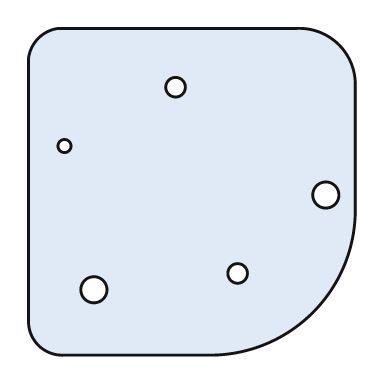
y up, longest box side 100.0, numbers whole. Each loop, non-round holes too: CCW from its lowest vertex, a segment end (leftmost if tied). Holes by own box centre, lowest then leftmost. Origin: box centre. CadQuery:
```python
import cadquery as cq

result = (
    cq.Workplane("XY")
    .moveTo(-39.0, -50.0)
    .lineTo(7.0, -50.0)
    .threePointArc((37.0, -37.0), (50.0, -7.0))
    .lineTo(50.0, 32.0)
    .threePointArc((45.0, 45.0), (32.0, 50.0))
    .lineTo(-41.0, 50.0)
    .threePointArc((-47.0, 47.0), (-50.0, 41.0))
    .lineTo(-50.0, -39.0)
    .threePointArc((-47.0, -47.0), (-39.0, -50.0))
    .close()
    .moveTo(-30.0, -30.0)
    .circle(4.0)
    .moveTo(14.0, -25.0)
    .circle(3.0)
    .moveTo(41.0, -1.0)
    .circle(4.0)
    .moveTo(-39.0, 14.0)
    .circle(2.0)
    .moveTo(-5.0, 32.0)
    .circle(3.0)
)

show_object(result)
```